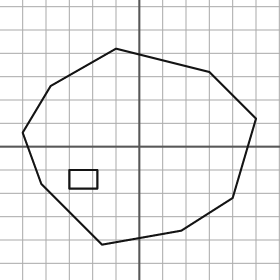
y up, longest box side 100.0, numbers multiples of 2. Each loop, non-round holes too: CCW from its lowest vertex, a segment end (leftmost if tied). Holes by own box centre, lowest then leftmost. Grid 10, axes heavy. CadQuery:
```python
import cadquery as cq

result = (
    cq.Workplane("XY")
    .moveTo(-16.0, -42.0)
    .lineTo(18.0, -36.0)
    .lineTo(40.0, -22.0)
    .lineTo(50.0, 12.0)
    .lineTo(30.0, 32.0)
    .lineTo(-10.0, 42.0)
    .lineTo(-38.0, 26.0)
    .lineTo(-50.0, 6.0)
    .lineTo(-42.0, -16.0)
    .close()
    .moveTo(-30.0, -18.0)
    .lineTo(-18.0, -18.0)
    .lineTo(-18.0, -10.0)
    .lineTo(-30.0, -10.0)
    .close()
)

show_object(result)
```